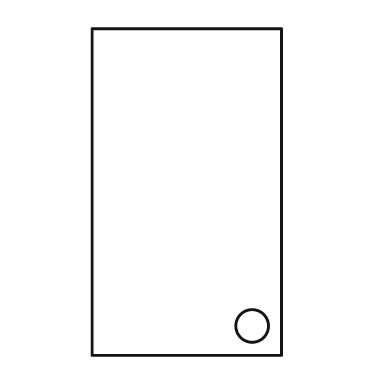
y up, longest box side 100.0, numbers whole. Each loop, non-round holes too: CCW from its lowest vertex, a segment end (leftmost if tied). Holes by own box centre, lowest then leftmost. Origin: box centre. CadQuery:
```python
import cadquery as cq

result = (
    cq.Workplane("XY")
    .moveTo(-29.0, -50.0)
    .lineTo(29.0, -50.0)
    .lineTo(29.0, 50.0)
    .lineTo(-29.0, 50.0)
    .close()
    .moveTo(20.0, -41.0)
    .circle(5.0)
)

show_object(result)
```